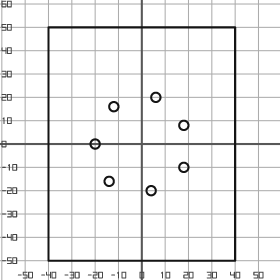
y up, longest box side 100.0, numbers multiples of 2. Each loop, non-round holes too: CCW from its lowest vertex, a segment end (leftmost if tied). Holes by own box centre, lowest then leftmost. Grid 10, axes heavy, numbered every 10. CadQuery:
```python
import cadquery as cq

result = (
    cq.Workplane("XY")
    .moveTo(-40.0, -50.0)
    .lineTo(40.0, -50.0)
    .lineTo(40.0, 50.0)
    .lineTo(-40.0, 50.0)
    .close()
    .moveTo(4.0, -20.0)
    .circle(2.0)
    .moveTo(-14.0, -16.0)
    .circle(2.0)
    .moveTo(18.0, -10.0)
    .circle(2.0)
    .moveTo(-20.0, 0.0)
    .circle(2.0)
    .moveTo(18.0, 8.0)
    .circle(2.0)
    .moveTo(-12.0, 16.0)
    .circle(2.0)
    .moveTo(6.0, 20.0)
    .circle(2.0)
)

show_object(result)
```